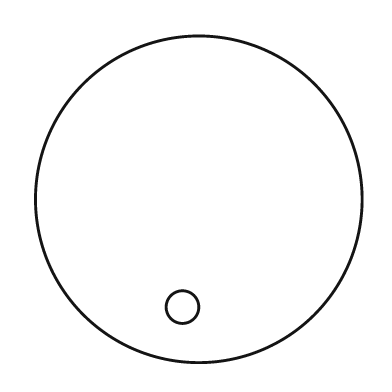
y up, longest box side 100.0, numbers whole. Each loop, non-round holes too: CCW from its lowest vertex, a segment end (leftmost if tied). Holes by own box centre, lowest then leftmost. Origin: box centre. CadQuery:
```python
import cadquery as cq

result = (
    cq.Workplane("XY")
    .moveTo(0.0, 0.0)
    .circle(50.0)
    .moveTo(-5.0, -33.0)
    .circle(5.0)
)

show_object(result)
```